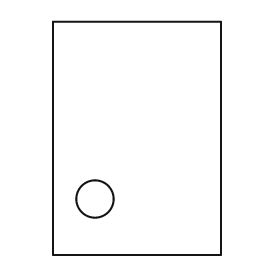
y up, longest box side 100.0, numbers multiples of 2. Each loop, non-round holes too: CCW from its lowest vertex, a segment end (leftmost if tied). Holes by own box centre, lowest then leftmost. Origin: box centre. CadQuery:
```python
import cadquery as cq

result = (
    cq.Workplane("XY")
    .moveTo(-36.0, -50.0)
    .lineTo(36.0, -50.0)
    .lineTo(36.0, 50.0)
    .lineTo(-36.0, 50.0)
    .close()
    .moveTo(-18.0, -26.0)
    .circle(8.0)
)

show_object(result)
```